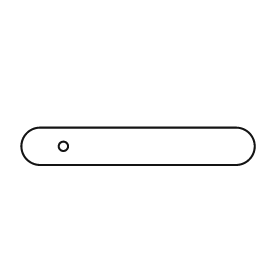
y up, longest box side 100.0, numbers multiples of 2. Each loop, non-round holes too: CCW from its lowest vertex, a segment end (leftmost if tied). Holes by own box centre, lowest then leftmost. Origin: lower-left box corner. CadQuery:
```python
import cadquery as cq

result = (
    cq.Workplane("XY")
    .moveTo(8.0, 0.0)
    .lineTo(92.0, 0.0)
    .threePointArc((100.0, 8.0), (92.0, 16.0))
    .lineTo(8.0, 16.0)
    .threePointArc((0.0, 8.0), (8.0, 0.0))
    .close()
    .moveTo(18.0, 8.0)
    .circle(2.0)
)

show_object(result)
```